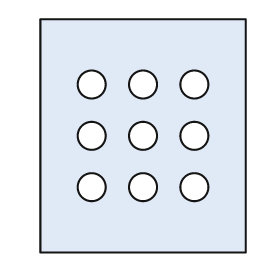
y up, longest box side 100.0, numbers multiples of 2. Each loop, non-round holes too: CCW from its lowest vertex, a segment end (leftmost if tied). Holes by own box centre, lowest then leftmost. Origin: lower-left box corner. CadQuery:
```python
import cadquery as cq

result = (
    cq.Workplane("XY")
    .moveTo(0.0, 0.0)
    .lineTo(88.0, 0.0)
    .lineTo(88.0, 100.0)
    .lineTo(0.0, 100.0)
    .close()
    .moveTo(22.0, 28.0)
    .circle(6.0)
    .moveTo(44.0, 28.0)
    .circle(6.0)
    .moveTo(66.0, 28.0)
    .circle(6.0)
    .moveTo(22.0, 50.0)
    .circle(6.0)
    .moveTo(44.0, 50.0)
    .circle(6.0)
    .moveTo(66.0, 50.0)
    .circle(6.0)
    .moveTo(22.0, 72.0)
    .circle(6.0)
    .moveTo(44.0, 72.0)
    .circle(6.0)
    .moveTo(66.0, 72.0)
    .circle(6.0)
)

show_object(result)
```